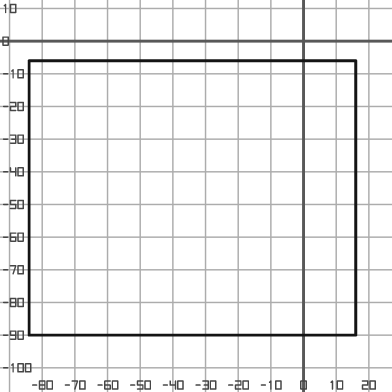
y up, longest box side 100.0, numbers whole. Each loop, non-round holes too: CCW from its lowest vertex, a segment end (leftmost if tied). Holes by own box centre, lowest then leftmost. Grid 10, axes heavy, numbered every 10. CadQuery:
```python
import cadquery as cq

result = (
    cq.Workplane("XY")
    .moveTo(-84.0, -90.0)
    .lineTo(16.0, -90.0)
    .lineTo(16.0, -6.0)
    .lineTo(-84.0, -6.0)
    .close()
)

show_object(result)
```